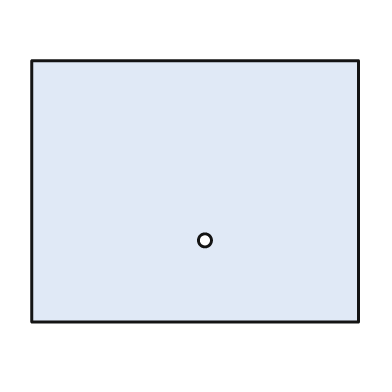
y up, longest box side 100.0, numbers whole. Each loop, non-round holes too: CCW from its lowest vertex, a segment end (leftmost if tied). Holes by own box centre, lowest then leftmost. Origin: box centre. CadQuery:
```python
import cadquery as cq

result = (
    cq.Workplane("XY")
    .moveTo(-50.0, -40.0)
    .lineTo(50.0, -40.0)
    .lineTo(50.0, 40.0)
    .lineTo(-50.0, 40.0)
    .close()
    .moveTo(3.0, -15.0)
    .circle(2.0)
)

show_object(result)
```